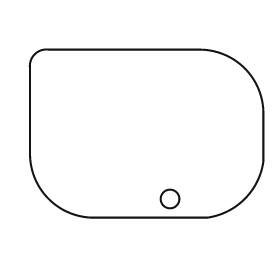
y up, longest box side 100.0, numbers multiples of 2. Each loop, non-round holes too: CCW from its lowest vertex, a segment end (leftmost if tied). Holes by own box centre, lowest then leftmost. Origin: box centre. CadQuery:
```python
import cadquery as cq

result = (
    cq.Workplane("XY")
    .moveTo(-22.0, -36.0)
    .lineTo(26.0, -36.0)
    .threePointArc((42.0, -28.0), (50.0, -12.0))
    .lineTo(50.0, 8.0)
    .threePointArc((42.0, 28.0), (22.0, 36.0))
    .lineTo(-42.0, 36.0)
    .threePointArc((-48.0, 34.0), (-50.0, 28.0))
    .lineTo(-50.0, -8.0)
    .threePointArc((-42.0, -28.0), (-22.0, -36.0))
    .close()
    .moveTo(10.0, -28.0)
    .circle(4.0)
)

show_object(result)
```